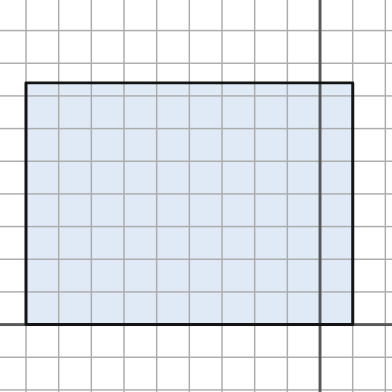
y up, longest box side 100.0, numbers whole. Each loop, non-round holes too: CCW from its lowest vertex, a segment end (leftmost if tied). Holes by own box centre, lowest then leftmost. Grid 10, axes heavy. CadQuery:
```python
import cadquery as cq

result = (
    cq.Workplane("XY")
    .moveTo(-90.0, 0.0)
    .lineTo(10.0, 0.0)
    .lineTo(10.0, 74.0)
    .lineTo(-90.0, 74.0)
    .close()
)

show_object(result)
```